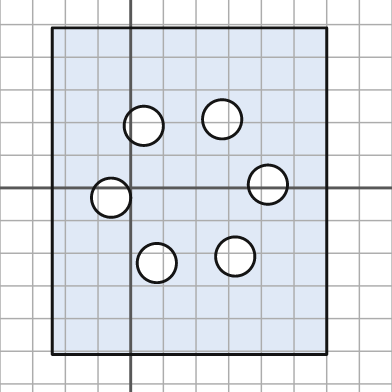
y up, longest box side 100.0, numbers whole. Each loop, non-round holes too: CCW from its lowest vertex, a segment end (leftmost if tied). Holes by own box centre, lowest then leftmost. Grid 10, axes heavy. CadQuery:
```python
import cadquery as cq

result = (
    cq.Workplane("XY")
    .moveTo(-24.0, -51.0)
    .lineTo(60.0, -51.0)
    .lineTo(60.0, 49.0)
    .lineTo(-24.0, 49.0)
    .close()
    .moveTo(8.0, -23.0)
    .circle(6.0)
    .moveTo(32.0, -21.0)
    .circle(6.0)
    .moveTo(-6.0, -3.0)
    .circle(6.0)
    .moveTo(42.0, 1.0)
    .circle(6.0)
    .moveTo(4.0, 19.0)
    .circle(6.0)
    .moveTo(28.0, 21.0)
    .circle(6.0)
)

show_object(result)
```